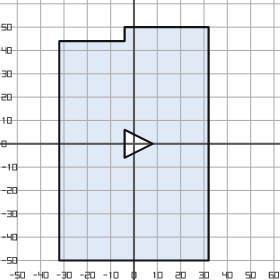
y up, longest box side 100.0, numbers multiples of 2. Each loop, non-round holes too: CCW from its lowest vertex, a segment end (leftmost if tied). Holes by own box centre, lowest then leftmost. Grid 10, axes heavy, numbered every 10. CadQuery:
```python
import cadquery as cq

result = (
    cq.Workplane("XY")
    .moveTo(-32.0, -50.0)
    .lineTo(32.0, -50.0)
    .lineTo(32.0, 50.0)
    .lineTo(-4.0, 50.0)
    .lineTo(-4.0, 44.0)
    .lineTo(-32.0, 44.0)
    .close()
    .moveTo(-4.0, -6.0)
    .lineTo(8.0, 0.0)
    .lineTo(-4.0, 6.0)
    .close()
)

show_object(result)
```